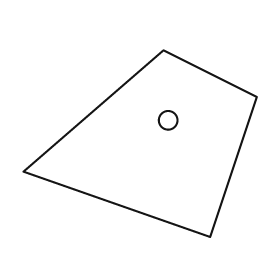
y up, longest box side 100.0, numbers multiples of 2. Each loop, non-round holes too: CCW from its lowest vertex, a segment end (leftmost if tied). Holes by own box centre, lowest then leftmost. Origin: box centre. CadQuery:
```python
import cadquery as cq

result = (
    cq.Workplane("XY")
    .moveTo(30.0, -40.0)
    .lineTo(50.0, 20.0)
    .lineTo(10.0, 40.0)
    .lineTo(-50.0, -12.0)
    .close()
    .moveTo(12.0, 10.0)
    .circle(4.0)
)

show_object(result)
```